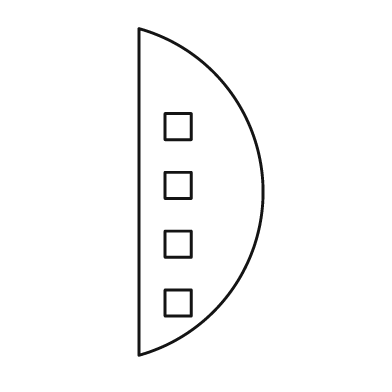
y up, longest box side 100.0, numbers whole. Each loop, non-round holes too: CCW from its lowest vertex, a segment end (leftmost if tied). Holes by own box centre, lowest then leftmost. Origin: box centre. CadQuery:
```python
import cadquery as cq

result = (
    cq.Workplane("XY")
    .moveTo(-19.0, -50.0)
    .threePointArc((19.0, 0.0), (-19.0, 50.0))
    .close()
    .moveTo(-11.0, -38.0)
    .lineTo(-3.0, -38.0)
    .lineTo(-3.0, -30.0)
    .lineTo(-11.0, -30.0)
    .close()
    .moveTo(-11.0, -20.0)
    .lineTo(-3.0, -20.0)
    .lineTo(-3.0, -12.0)
    .lineTo(-11.0, -12.0)
    .close()
    .moveTo(-11.0, -2.0)
    .lineTo(-3.0, -2.0)
    .lineTo(-3.0, 6.0)
    .lineTo(-11.0, 6.0)
    .close()
    .moveTo(-11.0, 16.0)
    .lineTo(-3.0, 16.0)
    .lineTo(-3.0, 24.0)
    .lineTo(-11.0, 24.0)
    .close()
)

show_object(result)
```